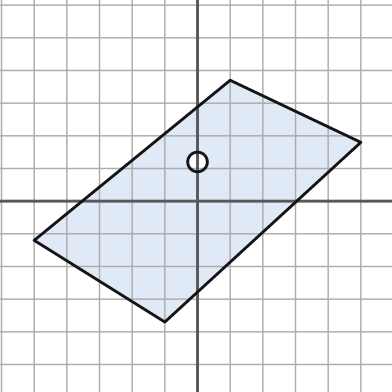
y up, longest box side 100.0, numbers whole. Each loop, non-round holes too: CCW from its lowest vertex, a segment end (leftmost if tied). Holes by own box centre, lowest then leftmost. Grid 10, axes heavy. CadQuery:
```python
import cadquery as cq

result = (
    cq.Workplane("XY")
    .moveTo(-10.0, -37.0)
    .lineTo(50.0, 18.0)
    .lineTo(10.0, 37.0)
    .lineTo(-50.0, -12.0)
    .close()
    .moveTo(0.0, 12.0)
    .circle(3.0)
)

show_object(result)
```